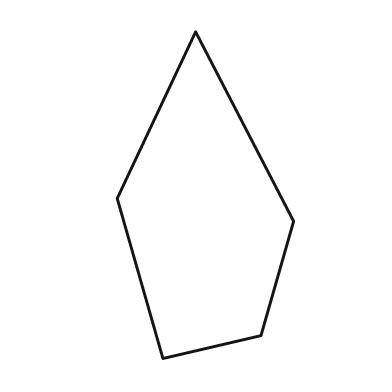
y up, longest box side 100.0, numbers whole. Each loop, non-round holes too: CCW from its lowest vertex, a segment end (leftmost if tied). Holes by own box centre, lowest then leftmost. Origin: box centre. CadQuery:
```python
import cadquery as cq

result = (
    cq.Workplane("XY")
    .moveTo(-13.0, -50.0)
    .lineTo(17.0, -43.0)
    .lineTo(27.0, -8.0)
    .lineTo(-3.0, 50.0)
    .lineTo(-27.0, -1.0)
    .close()
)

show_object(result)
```